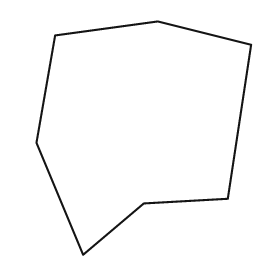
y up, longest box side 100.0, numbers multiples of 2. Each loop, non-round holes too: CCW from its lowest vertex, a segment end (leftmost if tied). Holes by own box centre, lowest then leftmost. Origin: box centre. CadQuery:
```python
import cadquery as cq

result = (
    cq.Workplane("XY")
    .moveTo(-26.0, -50.0)
    .lineTo(0.0, -28.0)
    .lineTo(36.0, -26.0)
    .lineTo(46.0, 40.0)
    .lineTo(6.0, 50.0)
    .lineTo(-38.0, 44.0)
    .lineTo(-46.0, -2.0)
    .close()
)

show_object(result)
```